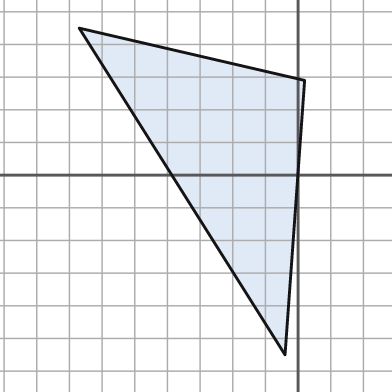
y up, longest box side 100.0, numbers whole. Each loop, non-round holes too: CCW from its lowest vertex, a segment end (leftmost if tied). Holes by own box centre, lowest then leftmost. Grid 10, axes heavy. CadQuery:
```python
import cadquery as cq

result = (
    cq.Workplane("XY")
    .moveTo(-4.0, -55.0)
    .lineTo(2.0, 29.0)
    .lineTo(-67.0, 45.0)
    .close()
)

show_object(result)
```